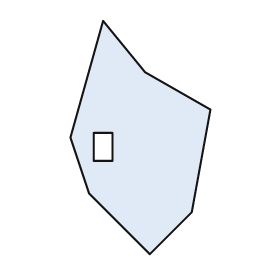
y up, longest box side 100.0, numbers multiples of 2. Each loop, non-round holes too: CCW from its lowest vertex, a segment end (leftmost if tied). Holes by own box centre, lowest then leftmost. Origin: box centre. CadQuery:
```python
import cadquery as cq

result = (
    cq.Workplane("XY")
    .moveTo(4.0, -50.0)
    .lineTo(22.0, -32.0)
    .lineTo(30.0, 12.0)
    .lineTo(2.0, 28.0)
    .lineTo(-16.0, 50.0)
    .lineTo(-30.0, 0.0)
    .lineTo(-22.0, -24.0)
    .close()
    .moveTo(-20.0, -10.0)
    .lineTo(-12.0, -10.0)
    .lineTo(-12.0, 2.0)
    .lineTo(-20.0, 2.0)
    .close()
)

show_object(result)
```